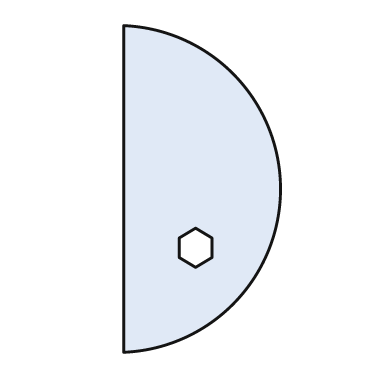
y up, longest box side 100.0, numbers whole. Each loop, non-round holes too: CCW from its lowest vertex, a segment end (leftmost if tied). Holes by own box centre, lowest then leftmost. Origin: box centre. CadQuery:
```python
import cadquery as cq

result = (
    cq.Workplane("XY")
    .moveTo(-24.0, -50.0)
    .threePointArc((24.0, 0.0), (-24.0, 50.0))
    .close()
    .moveTo(-2.0, -24.0)
    .lineTo(3.0, -21.0)
    .lineTo(3.0, -15.0)
    .lineTo(-2.0, -12.0)
    .lineTo(-7.0, -15.0)
    .lineTo(-7.0, -21.0)
    .close()
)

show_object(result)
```